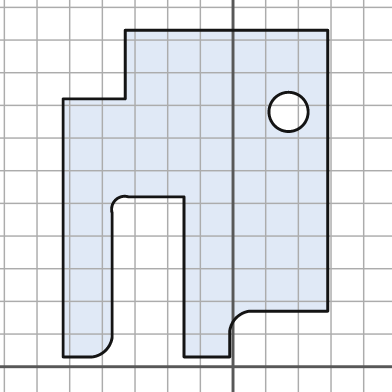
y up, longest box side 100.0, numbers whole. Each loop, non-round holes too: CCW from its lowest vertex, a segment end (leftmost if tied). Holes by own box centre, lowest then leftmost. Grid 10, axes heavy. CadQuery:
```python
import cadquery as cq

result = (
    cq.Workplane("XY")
    .moveTo(-52.0, 3.0)
    .lineTo(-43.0, 3.0)
    .threePointArc((-39.0, 5.0), (-37.0, 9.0))
    .lineTo(-37.0, 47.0)
    .threePointArc((-36.0, 51.0), (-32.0, 52.0))
    .lineTo(-15.0, 52.0)
    .lineTo(-15.0, 3.0)
    .lineTo(-1.0, 3.0)
    .lineTo(-1.0, 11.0)
    .threePointArc((1.0, 15.0), (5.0, 17.0))
    .lineTo(29.0, 17.0)
    .lineTo(29.0, 103.0)
    .lineTo(-33.0, 103.0)
    .lineTo(-33.0, 82.0)
    .lineTo(-52.0, 82.0)
    .close()
    .moveTo(17.0, 78.0)
    .circle(6.0)
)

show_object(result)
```